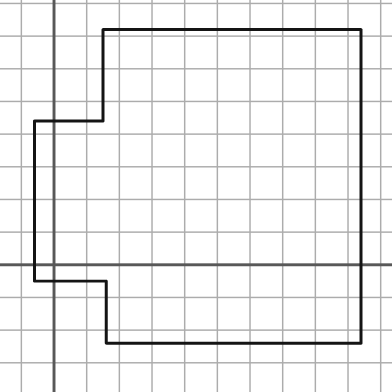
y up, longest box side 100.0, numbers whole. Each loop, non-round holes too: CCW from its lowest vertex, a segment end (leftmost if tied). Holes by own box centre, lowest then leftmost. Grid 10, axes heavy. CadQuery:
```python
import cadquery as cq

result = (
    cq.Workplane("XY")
    .moveTo(16.0, -24.0)
    .lineTo(94.0, -24.0)
    .lineTo(94.0, 72.0)
    .lineTo(15.0, 72.0)
    .lineTo(15.0, 44.0)
    .lineTo(-6.0, 44.0)
    .lineTo(-6.0, -5.0)
    .lineTo(16.0, -5.0)
    .close()
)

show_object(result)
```